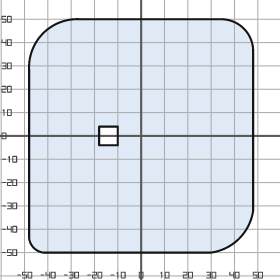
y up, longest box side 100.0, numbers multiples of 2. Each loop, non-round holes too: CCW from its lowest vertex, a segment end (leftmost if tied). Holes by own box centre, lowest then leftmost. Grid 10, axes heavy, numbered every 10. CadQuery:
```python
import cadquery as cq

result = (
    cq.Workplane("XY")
    .moveTo(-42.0, -50.0)
    .lineTo(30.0, -50.0)
    .threePointArc((42.0, -44.0), (48.0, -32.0))
    .lineTo(48.0, 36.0)
    .threePointArc((44.0, 46.0), (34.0, 50.0))
    .lineTo(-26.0, 50.0)
    .threePointArc((-42.0, 44.0), (-48.0, 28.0))
    .lineTo(-48.0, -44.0)
    .threePointArc((-46.0, -48.0), (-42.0, -50.0))
    .close()
    .moveTo(-18.0, -4.0)
    .lineTo(-10.0, -4.0)
    .lineTo(-10.0, 4.0)
    .lineTo(-18.0, 4.0)
    .close()
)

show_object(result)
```